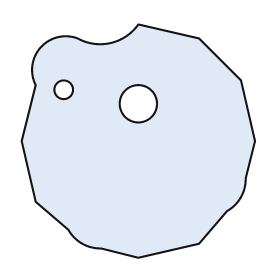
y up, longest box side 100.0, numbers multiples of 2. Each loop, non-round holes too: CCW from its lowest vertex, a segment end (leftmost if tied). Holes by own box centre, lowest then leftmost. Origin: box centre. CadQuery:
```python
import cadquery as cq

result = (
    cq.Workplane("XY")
    .moveTo(0.0, -50.0)
    .lineTo(26.0, -44.0)
    .lineTo(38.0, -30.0)
    .threePointArc((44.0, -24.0), (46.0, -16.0))
    .lineTo(50.0, 0.0)
    .lineTo(44.0, 26.0)
    .lineTo(26.0, 44.0)
    .lineTo(0.0, 50.0)
    .threePointArc((-12.0, 42.0), (-26.0, 44.0))
    .threePointArc((-42.0, 40.0), (-44.0, 24.0))
    .lineTo(-50.0, 0.0)
    .lineTo(-44.0, -26.0)
    .lineTo(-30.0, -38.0)
    .threePointArc((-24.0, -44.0), (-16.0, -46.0))
    .close()
    .moveTo(0.0, 16.0)
    .circle(8.0)
    .moveTo(-32.0, 22.0)
    .circle(4.0)
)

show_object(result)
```